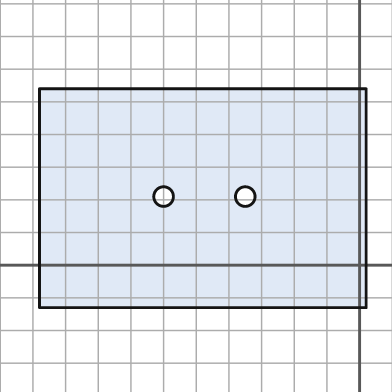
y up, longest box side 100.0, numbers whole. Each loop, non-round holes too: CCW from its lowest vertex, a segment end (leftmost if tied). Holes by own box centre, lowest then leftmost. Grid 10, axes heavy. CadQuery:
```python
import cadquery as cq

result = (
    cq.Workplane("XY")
    .moveTo(-98.0, -13.0)
    .lineTo(2.0, -13.0)
    .lineTo(2.0, 54.0)
    .lineTo(-98.0, 54.0)
    .close()
    .moveTo(-60.0, 21.0)
    .circle(3.0)
    .moveTo(-35.0, 21.0)
    .circle(3.0)
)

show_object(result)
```